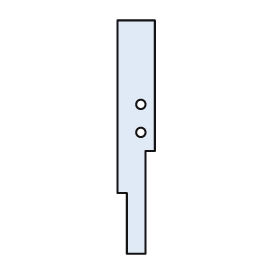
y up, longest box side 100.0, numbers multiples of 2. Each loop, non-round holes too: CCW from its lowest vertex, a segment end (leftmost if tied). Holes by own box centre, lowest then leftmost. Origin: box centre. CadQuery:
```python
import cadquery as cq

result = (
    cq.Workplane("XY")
    .moveTo(-4.0, -50.0)
    .lineTo(4.0, -50.0)
    .lineTo(4.0, -6.0)
    .lineTo(8.0, -6.0)
    .lineTo(8.0, 50.0)
    .lineTo(-8.0, 50.0)
    .lineTo(-8.0, -24.0)
    .lineTo(-4.0, -24.0)
    .close()
    .moveTo(2.0, 2.0)
    .circle(2.0)
    .moveTo(2.0, 14.0)
    .circle(2.0)
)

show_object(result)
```